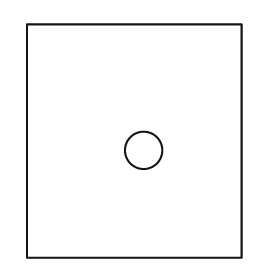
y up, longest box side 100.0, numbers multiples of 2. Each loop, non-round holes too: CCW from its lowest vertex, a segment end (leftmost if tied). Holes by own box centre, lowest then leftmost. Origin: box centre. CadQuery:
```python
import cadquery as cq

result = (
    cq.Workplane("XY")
    .moveTo(-46.0, -50.0)
    .lineTo(46.0, -50.0)
    .lineTo(46.0, 50.0)
    .lineTo(-46.0, 50.0)
    .close()
    .moveTo(4.0, -4.0)
    .circle(8.0)
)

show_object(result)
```